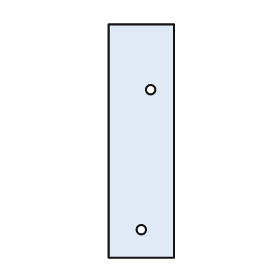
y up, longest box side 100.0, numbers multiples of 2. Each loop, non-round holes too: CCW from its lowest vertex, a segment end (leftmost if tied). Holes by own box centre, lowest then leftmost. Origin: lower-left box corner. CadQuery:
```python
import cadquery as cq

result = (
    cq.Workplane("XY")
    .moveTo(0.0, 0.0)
    .lineTo(28.0, 0.0)
    .lineTo(28.0, 100.0)
    .lineTo(0.0, 100.0)
    .close()
    .moveTo(14.0, 12.0)
    .circle(2.0)
    .moveTo(18.0, 72.0)
    .circle(2.0)
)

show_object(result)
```